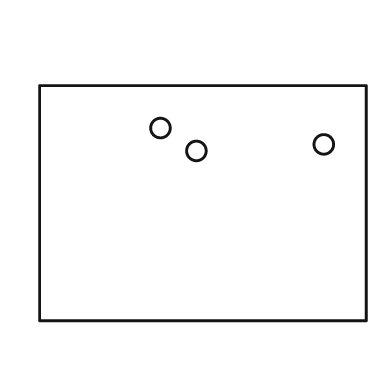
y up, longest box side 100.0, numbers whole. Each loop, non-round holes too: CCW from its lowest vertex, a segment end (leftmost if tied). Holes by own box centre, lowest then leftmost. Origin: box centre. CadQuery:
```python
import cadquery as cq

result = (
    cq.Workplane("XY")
    .moveTo(-50.0, -36.0)
    .lineTo(50.0, -36.0)
    .lineTo(50.0, 36.0)
    .lineTo(-50.0, 36.0)
    .close()
    .moveTo(-2.0, 16.0)
    .circle(3.0)
    .moveTo(37.0, 18.0)
    .circle(3.0)
    .moveTo(-13.0, 23.0)
    .circle(3.0)
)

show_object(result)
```